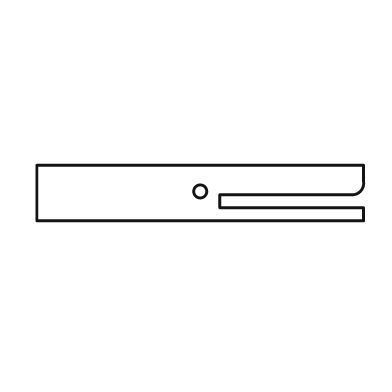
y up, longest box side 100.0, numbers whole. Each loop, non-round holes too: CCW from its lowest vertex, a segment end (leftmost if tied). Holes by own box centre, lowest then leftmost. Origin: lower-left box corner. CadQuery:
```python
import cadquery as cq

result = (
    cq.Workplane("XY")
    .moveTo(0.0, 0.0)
    .lineTo(100.0, 0.0)
    .lineTo(100.0, 4.0)
    .lineTo(56.0, 4.0)
    .lineTo(56.0, 8.0)
    .lineTo(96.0, 8.0)
    .threePointArc((99.0, 9.0), (100.0, 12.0))
    .lineTo(100.0, 17.0)
    .lineTo(0.0, 17.0)
    .close()
    .moveTo(50.0, 9.0)
    .circle(2.0)
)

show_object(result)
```